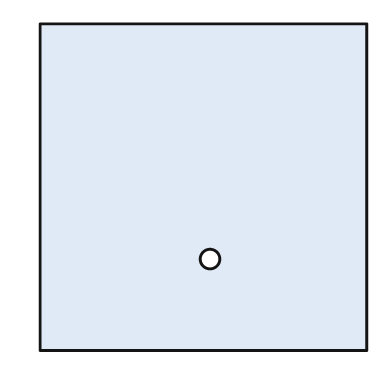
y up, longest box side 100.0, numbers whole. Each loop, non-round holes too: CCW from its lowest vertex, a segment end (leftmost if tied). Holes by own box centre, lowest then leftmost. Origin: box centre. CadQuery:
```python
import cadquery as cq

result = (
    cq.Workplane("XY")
    .moveTo(-50.0, -50.0)
    .lineTo(50.0, -50.0)
    .lineTo(50.0, 50.0)
    .lineTo(-50.0, 50.0)
    .close()
    .moveTo(2.0, -22.0)
    .circle(3.0)
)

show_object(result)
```